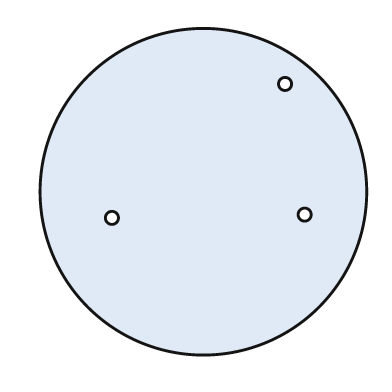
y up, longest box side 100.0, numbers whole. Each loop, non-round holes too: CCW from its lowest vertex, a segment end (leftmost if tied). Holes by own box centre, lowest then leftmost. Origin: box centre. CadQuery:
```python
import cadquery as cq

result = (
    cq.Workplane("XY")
    .moveTo(0.0, 0.0)
    .circle(50.0)
    .moveTo(-28.0, -8.0)
    .circle(2.0)
    .moveTo(31.0, -7.0)
    .circle(2.0)
    .moveTo(25.0, 33.0)
    .circle(2.0)
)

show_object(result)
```